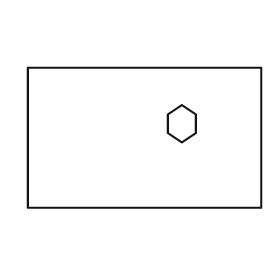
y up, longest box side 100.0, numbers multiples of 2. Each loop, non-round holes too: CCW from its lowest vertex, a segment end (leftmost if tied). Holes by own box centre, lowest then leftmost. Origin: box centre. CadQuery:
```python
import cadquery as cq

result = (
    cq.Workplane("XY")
    .moveTo(-50.0, -30.0)
    .lineTo(50.0, -30.0)
    .lineTo(50.0, 30.0)
    .lineTo(-50.0, 30.0)
    .close()
    .moveTo(16.0, -2.0)
    .lineTo(22.0, 2.0)
    .lineTo(22.0, 10.0)
    .lineTo(16.0, 14.0)
    .lineTo(10.0, 10.0)
    .lineTo(10.0, 2.0)
    .close()
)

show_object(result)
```